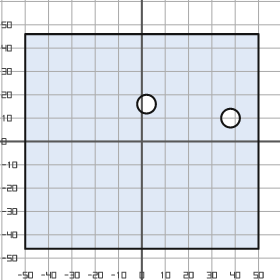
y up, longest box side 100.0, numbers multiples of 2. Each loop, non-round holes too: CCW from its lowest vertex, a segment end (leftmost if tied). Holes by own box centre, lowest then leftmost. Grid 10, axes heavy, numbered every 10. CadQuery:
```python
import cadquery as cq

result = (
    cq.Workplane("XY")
    .moveTo(-50.0, -46.0)
    .lineTo(50.0, -46.0)
    .lineTo(50.0, 46.0)
    .lineTo(-50.0, 46.0)
    .close()
    .moveTo(38.0, 10.0)
    .circle(4.0)
    .moveTo(2.0, 16.0)
    .circle(4.0)
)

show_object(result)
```